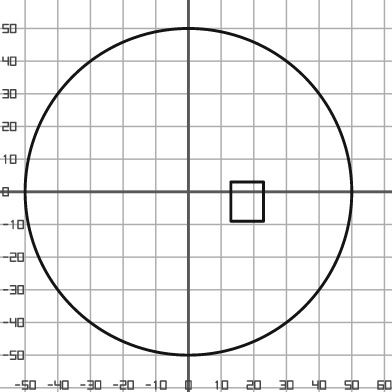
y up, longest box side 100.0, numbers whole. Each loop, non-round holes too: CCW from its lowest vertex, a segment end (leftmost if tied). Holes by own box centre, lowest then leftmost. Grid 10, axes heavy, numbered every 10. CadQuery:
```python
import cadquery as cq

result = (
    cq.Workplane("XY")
    .moveTo(0.0, 0.0)
    .circle(50.0)
    .moveTo(13.0, -9.0)
    .lineTo(23.0, -9.0)
    .lineTo(23.0, 3.0)
    .lineTo(13.0, 3.0)
    .close()
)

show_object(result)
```